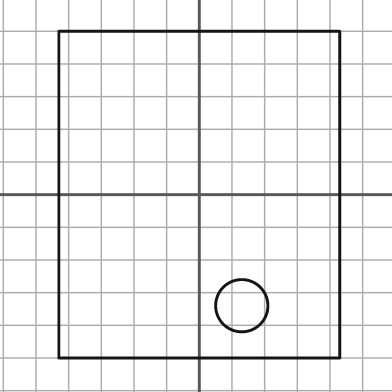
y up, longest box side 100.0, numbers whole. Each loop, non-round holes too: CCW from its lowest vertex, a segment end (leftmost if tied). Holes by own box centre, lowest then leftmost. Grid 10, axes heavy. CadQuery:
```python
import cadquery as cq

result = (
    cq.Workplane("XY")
    .moveTo(-43.0, -50.0)
    .lineTo(43.0, -50.0)
    .lineTo(43.0, 50.0)
    .lineTo(-43.0, 50.0)
    .close()
    .moveTo(13.0, -34.0)
    .circle(8.0)
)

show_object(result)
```